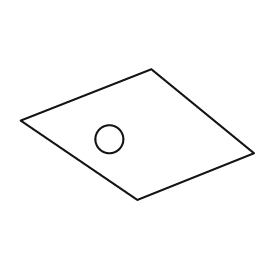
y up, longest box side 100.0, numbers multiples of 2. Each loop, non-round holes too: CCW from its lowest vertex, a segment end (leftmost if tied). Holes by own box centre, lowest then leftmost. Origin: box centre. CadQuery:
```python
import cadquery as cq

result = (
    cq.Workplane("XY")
    .moveTo(0.0, -28.0)
    .lineTo(50.0, -8.0)
    .lineTo(6.0, 28.0)
    .lineTo(-50.0, 6.0)
    .close()
    .moveTo(-12.0, -2.0)
    .circle(6.0)
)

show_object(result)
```